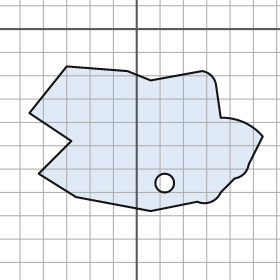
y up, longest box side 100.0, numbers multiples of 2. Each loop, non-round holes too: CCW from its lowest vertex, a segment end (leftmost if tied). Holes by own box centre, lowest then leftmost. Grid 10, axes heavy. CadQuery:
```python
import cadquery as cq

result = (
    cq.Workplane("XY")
    .moveTo(6.0, -78.0)
    .lineTo(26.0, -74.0)
    .threePointArc((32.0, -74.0), (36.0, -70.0))
    .lineTo(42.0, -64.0)
    .threePointArc((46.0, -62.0), (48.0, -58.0))
    .lineTo(54.0, -46.0)
    .threePointArc((46.0, -40.0), (36.0, -38.0))
    .lineTo(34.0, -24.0)
    .threePointArc((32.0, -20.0), (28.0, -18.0))
    .lineTo(6.0, -22.0)
    .lineTo(-4.0, -18.0)
    .lineTo(-30.0, -16.0)
    .lineTo(-46.0, -36.0)
    .lineTo(-28.0, -48.0)
    .lineTo(-42.0, -62.0)
    .lineTo(-26.0, -72.0)
    .close()
    .moveTo(12.0, -66.0)
    .circle(4.0)
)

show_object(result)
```